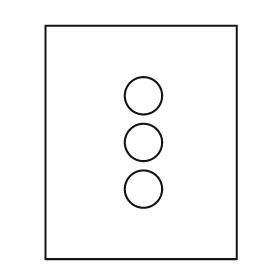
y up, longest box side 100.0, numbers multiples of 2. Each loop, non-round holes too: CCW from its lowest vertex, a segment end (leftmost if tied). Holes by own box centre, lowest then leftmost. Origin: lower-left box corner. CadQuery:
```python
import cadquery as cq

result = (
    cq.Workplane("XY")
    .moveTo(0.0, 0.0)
    .lineTo(82.0, 0.0)
    .lineTo(82.0, 100.0)
    .lineTo(0.0, 100.0)
    .close()
    .moveTo(42.0, 30.0)
    .circle(8.0)
    .moveTo(42.0, 50.0)
    .circle(8.0)
    .moveTo(42.0, 70.0)
    .circle(8.0)
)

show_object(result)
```